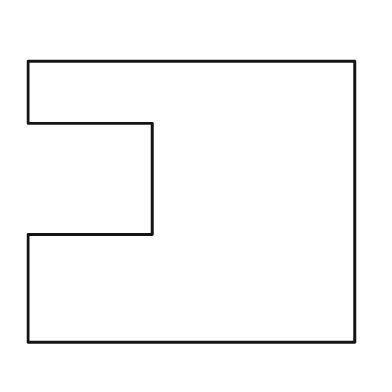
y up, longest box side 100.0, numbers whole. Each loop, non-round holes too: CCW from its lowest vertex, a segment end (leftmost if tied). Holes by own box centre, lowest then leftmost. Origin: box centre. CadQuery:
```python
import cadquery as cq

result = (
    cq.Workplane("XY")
    .moveTo(-50.0, -43.0)
    .lineTo(50.0, -43.0)
    .lineTo(50.0, 43.0)
    .lineTo(-50.0, 43.0)
    .lineTo(-50.0, 24.0)
    .lineTo(-12.0, 24.0)
    .lineTo(-12.0, -10.0)
    .lineTo(-50.0, -10.0)
    .close()
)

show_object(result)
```